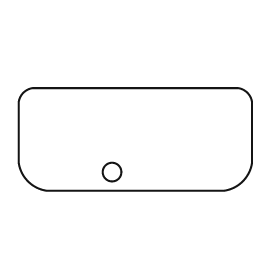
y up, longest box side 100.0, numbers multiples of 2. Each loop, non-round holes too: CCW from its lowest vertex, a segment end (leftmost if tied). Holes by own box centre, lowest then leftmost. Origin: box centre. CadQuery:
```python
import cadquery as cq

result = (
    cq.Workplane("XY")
    .moveTo(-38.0, -22.0)
    .lineTo(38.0, -22.0)
    .threePointArc((46.0, -18.0), (50.0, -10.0))
    .lineTo(50.0, 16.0)
    .threePointArc((48.0, 20.0), (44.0, 22.0))
    .lineTo(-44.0, 22.0)
    .threePointArc((-48.0, 20.0), (-50.0, 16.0))
    .lineTo(-50.0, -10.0)
    .threePointArc((-46.0, -18.0), (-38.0, -22.0))
    .close()
    .moveTo(-10.0, -14.0)
    .circle(4.0)
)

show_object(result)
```